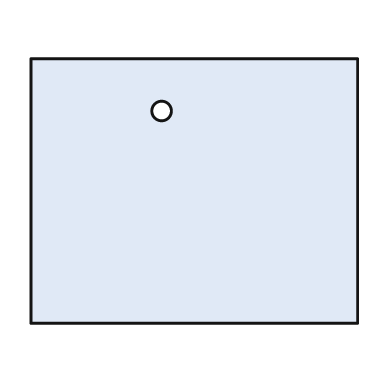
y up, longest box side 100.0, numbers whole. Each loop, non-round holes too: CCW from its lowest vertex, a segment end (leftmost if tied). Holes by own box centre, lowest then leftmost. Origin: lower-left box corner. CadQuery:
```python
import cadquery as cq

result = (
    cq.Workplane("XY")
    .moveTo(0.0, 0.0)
    .lineTo(100.0, 0.0)
    .lineTo(100.0, 81.0)
    .lineTo(0.0, 81.0)
    .close()
    .moveTo(40.0, 65.0)
    .circle(3.0)
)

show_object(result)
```